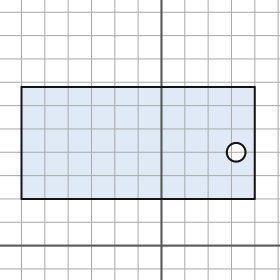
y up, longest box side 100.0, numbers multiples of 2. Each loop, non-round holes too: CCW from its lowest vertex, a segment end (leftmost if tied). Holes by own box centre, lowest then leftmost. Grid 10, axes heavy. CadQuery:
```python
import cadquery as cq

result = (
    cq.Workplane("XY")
    .moveTo(-60.0, 20.0)
    .lineTo(40.0, 20.0)
    .lineTo(40.0, 68.0)
    .lineTo(-60.0, 68.0)
    .close()
    .moveTo(32.0, 40.0)
    .circle(4.0)
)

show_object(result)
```